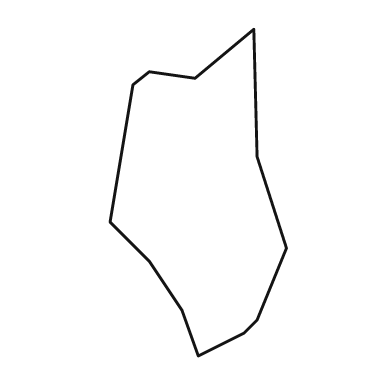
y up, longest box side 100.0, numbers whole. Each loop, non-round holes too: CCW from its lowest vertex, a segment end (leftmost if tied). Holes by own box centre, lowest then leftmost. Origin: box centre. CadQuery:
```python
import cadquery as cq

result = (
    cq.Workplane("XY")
    .moveTo(0.0, -50.0)
    .lineTo(14.0, -43.0)
    .lineTo(18.0, -39.0)
    .lineTo(27.0, -17.0)
    .lineTo(18.0, 11.0)
    .lineTo(17.0, 50.0)
    .lineTo(-1.0, 35.0)
    .lineTo(-15.0, 37.0)
    .lineTo(-20.0, 33.0)
    .lineTo(-27.0, -9.0)
    .lineTo(-15.0, -21.0)
    .lineTo(-5.0, -36.0)
    .close()
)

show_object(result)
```